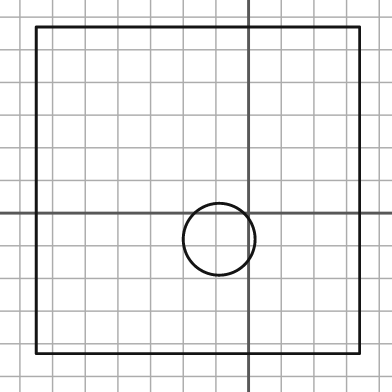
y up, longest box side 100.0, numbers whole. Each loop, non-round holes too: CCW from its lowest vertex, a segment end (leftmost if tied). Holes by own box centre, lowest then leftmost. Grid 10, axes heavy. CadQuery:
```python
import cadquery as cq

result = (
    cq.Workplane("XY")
    .moveTo(-65.0, -43.0)
    .lineTo(34.0, -43.0)
    .lineTo(34.0, 57.0)
    .lineTo(-65.0, 57.0)
    .close()
    .moveTo(-9.0, -8.0)
    .circle(11.0)
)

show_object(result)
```